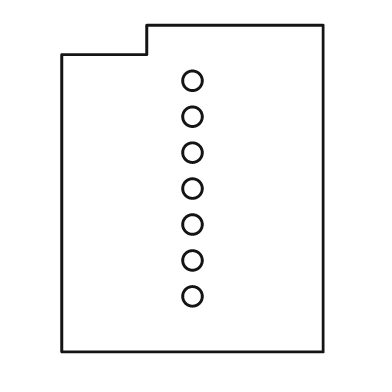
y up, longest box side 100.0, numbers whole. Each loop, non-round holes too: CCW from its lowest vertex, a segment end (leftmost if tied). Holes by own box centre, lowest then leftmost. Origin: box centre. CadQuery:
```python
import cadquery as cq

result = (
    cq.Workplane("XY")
    .moveTo(-40.0, -50.0)
    .lineTo(40.0, -50.0)
    .lineTo(40.0, 50.0)
    .lineTo(-14.0, 50.0)
    .lineTo(-14.0, 41.0)
    .lineTo(-40.0, 41.0)
    .close()
    .moveTo(0.0, -33.0)
    .circle(3.0)
    .moveTo(0.0, -22.0)
    .circle(3.0)
    .moveTo(0.0, -11.0)
    .circle(3.0)
    .moveTo(0.0, 0.0)
    .circle(3.0)
    .moveTo(0.0, 11.0)
    .circle(3.0)
    .moveTo(0.0, 22.0)
    .circle(3.0)
    .moveTo(0.0, 33.0)
    .circle(3.0)
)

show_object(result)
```